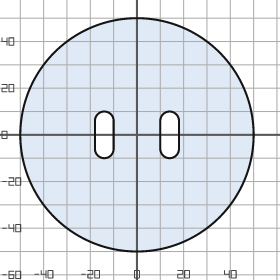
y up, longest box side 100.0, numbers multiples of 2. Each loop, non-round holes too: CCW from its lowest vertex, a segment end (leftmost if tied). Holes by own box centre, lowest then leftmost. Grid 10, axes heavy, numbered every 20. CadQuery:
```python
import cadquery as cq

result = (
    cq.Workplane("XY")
    .moveTo(0.0, 0.0)
    .circle(50.0)
    .moveTo(-18.0, -6.0)
    .threePointArc((-14.0, -10.0), (-10.0, -6.0))
    .lineTo(-10.0, 6.0)
    .threePointArc((-14.0, 10.0), (-18.0, 6.0))
    .close()
    .moveTo(10.0, -6.0)
    .threePointArc((14.0, -10.0), (18.0, -6.0))
    .lineTo(18.0, 6.0)
    .threePointArc((14.0, 10.0), (10.0, 6.0))
    .close()
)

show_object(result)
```